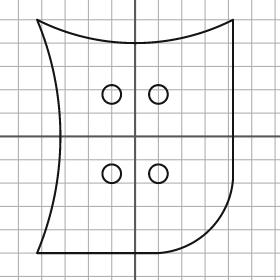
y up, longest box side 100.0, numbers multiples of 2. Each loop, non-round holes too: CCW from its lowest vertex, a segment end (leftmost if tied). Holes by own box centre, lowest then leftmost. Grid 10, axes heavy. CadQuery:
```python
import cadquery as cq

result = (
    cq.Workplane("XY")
    .moveTo(-42.0, -50.0)
    .lineTo(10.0, -50.0)
    .threePointArc((32.0, -40.0), (42.0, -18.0))
    .lineTo(42.0, 50.0)
    .threePointArc((0.0, 40.0), (-42.0, 50.0))
    .threePointArc((-32.0, 0.0), (-42.0, -50.0))
    .close()
    .moveTo(-10.0, -16.0)
    .circle(4.0)
    .moveTo(10.0, -16.0)
    .circle(4.0)
    .moveTo(-10.0, 18.0)
    .circle(4.0)
    .moveTo(10.0, 18.0)
    .circle(4.0)
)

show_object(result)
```